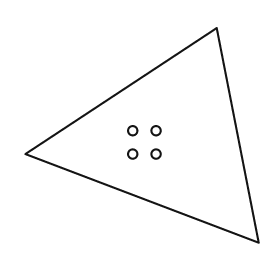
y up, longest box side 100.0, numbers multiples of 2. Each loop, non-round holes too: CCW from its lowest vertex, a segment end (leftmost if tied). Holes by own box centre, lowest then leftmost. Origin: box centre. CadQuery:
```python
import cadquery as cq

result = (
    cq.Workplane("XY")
    .moveTo(50.0, -46.0)
    .lineTo(32.0, 46.0)
    .lineTo(-50.0, -8.0)
    .close()
    .moveTo(-4.0, -8.0)
    .circle(2.0)
    .moveTo(6.0, -8.0)
    .circle(2.0)
    .moveTo(-4.0, 2.0)
    .circle(2.0)
    .moveTo(6.0, 2.0)
    .circle(2.0)
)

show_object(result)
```